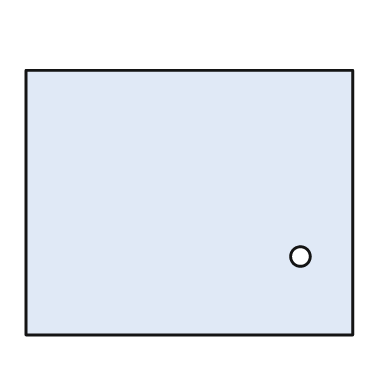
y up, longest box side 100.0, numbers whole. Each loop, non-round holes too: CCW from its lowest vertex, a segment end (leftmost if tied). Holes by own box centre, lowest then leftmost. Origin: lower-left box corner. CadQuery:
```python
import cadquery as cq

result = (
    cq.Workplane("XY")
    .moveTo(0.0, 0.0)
    .lineTo(100.0, 0.0)
    .lineTo(100.0, 81.0)
    .lineTo(0.0, 81.0)
    .close()
    .moveTo(84.0, 24.0)
    .circle(3.0)
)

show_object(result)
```